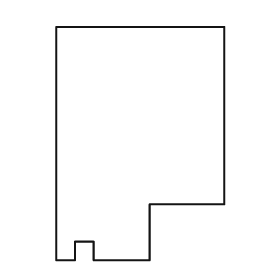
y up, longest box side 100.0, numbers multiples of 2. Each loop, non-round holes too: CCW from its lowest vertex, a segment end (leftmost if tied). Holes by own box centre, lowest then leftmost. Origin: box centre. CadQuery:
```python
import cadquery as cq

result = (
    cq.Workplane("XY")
    .moveTo(-36.0, -50.0)
    .lineTo(-28.0, -50.0)
    .lineTo(-28.0, -42.0)
    .lineTo(-20.0, -42.0)
    .lineTo(-20.0, -50.0)
    .lineTo(4.0, -50.0)
    .lineTo(4.0, -26.0)
    .lineTo(36.0, -26.0)
    .lineTo(36.0, 50.0)
    .lineTo(-36.0, 50.0)
    .close()
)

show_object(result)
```